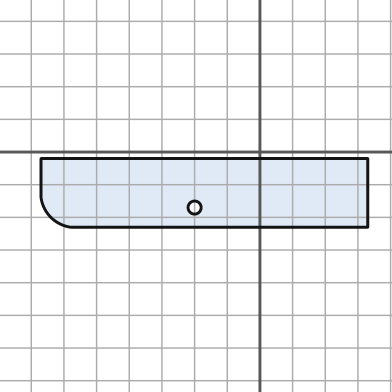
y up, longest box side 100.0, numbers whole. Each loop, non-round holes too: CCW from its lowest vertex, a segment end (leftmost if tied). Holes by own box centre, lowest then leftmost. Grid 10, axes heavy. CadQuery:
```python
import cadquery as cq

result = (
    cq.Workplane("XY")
    .moveTo(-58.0, -23.0)
    .lineTo(33.0, -23.0)
    .lineTo(33.0, -2.0)
    .lineTo(-67.0, -2.0)
    .lineTo(-67.0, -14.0)
    .threePointArc((-64.0, -20.0), (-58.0, -23.0))
    .close()
    .moveTo(-20.0, -17.0)
    .circle(2.0)
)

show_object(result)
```